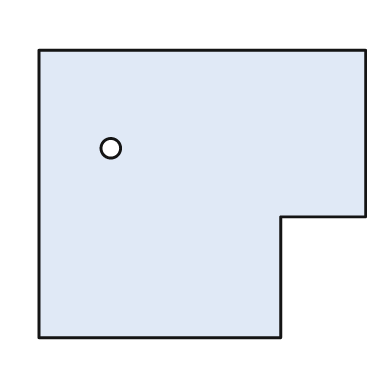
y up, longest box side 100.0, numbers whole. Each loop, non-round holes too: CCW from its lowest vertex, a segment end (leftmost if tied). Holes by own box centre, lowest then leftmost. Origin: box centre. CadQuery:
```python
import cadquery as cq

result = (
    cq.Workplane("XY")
    .moveTo(-50.0, -44.0)
    .lineTo(24.0, -44.0)
    .lineTo(24.0, -7.0)
    .lineTo(50.0, -7.0)
    .lineTo(50.0, 44.0)
    .lineTo(-50.0, 44.0)
    .close()
    .moveTo(-28.0, 14.0)
    .circle(3.0)
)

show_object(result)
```